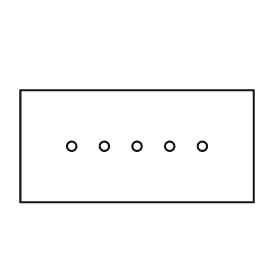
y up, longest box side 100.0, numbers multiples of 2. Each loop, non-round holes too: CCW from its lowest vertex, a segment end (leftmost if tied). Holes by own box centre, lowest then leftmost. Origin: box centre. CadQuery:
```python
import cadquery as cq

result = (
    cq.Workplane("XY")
    .moveTo(-50.0, -24.0)
    .lineTo(50.0, -24.0)
    .lineTo(50.0, 24.0)
    .lineTo(-50.0, 24.0)
    .close()
    .moveTo(-28.0, 0.0)
    .circle(2.0)
    .moveTo(-14.0, 0.0)
    .circle(2.0)
    .moveTo(0.0, 0.0)
    .circle(2.0)
    .moveTo(14.0, 0.0)
    .circle(2.0)
    .moveTo(28.0, 0.0)
    .circle(2.0)
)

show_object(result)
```